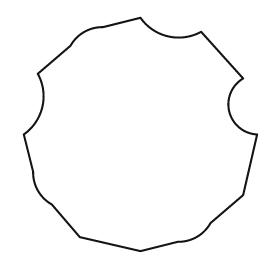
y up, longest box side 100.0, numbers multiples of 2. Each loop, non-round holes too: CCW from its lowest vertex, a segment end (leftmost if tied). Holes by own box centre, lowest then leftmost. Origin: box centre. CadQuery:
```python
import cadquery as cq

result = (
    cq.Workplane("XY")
    .moveTo(0.0, -50.0)
    .lineTo(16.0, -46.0)
    .threePointArc((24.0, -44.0), (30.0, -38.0))
    .lineTo(44.0, -26.0)
    .lineTo(50.0, 0.0)
    .threePointArc((38.0, 10.0), (44.0, 24.0))
    .lineTo(26.0, 44.0)
    .threePointArc((12.0, 42.0), (0.0, 50.0))
    .lineTo(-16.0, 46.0)
    .threePointArc((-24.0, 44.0), (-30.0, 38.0))
    .lineTo(-44.0, 26.0)
    .threePointArc((-42.0, 12.0), (-50.0, 0.0))
    .lineTo(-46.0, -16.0)
    .threePointArc((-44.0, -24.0), (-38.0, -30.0))
    .lineTo(-26.0, -44.0)
    .close()
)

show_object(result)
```